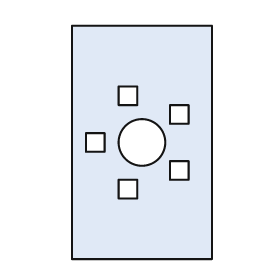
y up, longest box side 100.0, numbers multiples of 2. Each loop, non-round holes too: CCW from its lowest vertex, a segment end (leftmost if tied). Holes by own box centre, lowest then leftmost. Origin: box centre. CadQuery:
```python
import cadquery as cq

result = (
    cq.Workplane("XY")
    .moveTo(-30.0, -50.0)
    .lineTo(30.0, -50.0)
    .lineTo(30.0, 50.0)
    .lineTo(-30.0, 50.0)
    .close()
    .moveTo(-10.0, -24.0)
    .lineTo(-2.0, -24.0)
    .lineTo(-2.0, -16.0)
    .lineTo(-10.0, -16.0)
    .close()
    .moveTo(12.0, -16.0)
    .lineTo(20.0, -16.0)
    .lineTo(20.0, -8.0)
    .lineTo(12.0, -8.0)
    .close()
    .moveTo(-24.0, -4.0)
    .lineTo(-16.0, -4.0)
    .lineTo(-16.0, 4.0)
    .lineTo(-24.0, 4.0)
    .close()
    .moveTo(0.0, 0.0)
    .circle(10.0)
    .moveTo(12.0, 8.0)
    .lineTo(20.0, 8.0)
    .lineTo(20.0, 16.0)
    .lineTo(12.0, 16.0)
    .close()
    .moveTo(-10.0, 16.0)
    .lineTo(-2.0, 16.0)
    .lineTo(-2.0, 24.0)
    .lineTo(-10.0, 24.0)
    .close()
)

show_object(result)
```